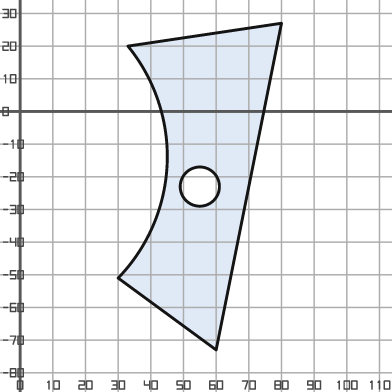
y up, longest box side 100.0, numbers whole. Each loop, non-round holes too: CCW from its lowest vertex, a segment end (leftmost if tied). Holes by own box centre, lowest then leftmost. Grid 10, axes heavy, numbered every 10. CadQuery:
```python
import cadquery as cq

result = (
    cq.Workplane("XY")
    .moveTo(60.0, -73.0)
    .lineTo(80.0, 27.0)
    .lineTo(33.0, 20.0)
    .threePointArc((45.0, -16.0), (30.0, -51.0))
    .close()
    .moveTo(55.0, -23.0)
    .circle(6.0)
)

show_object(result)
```